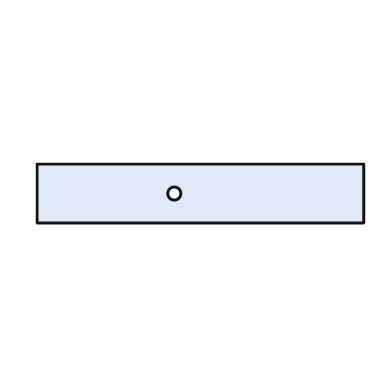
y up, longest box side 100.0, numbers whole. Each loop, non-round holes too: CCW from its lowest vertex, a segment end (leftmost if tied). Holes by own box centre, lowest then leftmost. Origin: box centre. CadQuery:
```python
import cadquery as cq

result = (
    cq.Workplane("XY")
    .moveTo(-50.0, -9.0)
    .lineTo(50.0, -9.0)
    .lineTo(50.0, 9.0)
    .lineTo(-50.0, 9.0)
    .close()
    .moveTo(-8.0, 0.0)
    .circle(2.0)
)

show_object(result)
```